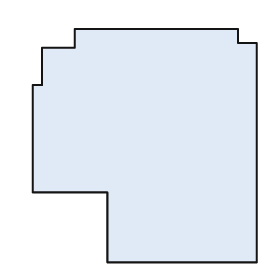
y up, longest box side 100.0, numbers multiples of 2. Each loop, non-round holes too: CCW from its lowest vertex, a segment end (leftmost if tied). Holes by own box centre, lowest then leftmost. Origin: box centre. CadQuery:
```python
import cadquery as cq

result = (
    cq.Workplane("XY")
    .moveTo(-16.0, -50.0)
    .lineTo(48.0, -50.0)
    .lineTo(48.0, 44.0)
    .lineTo(40.0, 44.0)
    .lineTo(40.0, 50.0)
    .lineTo(-30.0, 50.0)
    .lineTo(-30.0, 42.0)
    .lineTo(-44.0, 42.0)
    .lineTo(-44.0, 26.0)
    .lineTo(-48.0, 26.0)
    .lineTo(-48.0, -20.0)
    .lineTo(-16.0, -20.0)
    .close()
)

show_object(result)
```